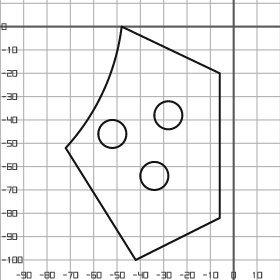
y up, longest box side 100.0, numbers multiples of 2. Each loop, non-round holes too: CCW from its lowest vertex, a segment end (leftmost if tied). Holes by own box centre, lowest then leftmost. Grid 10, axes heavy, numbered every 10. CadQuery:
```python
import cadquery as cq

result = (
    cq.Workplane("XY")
    .moveTo(-42.0, -100.0)
    .lineTo(-6.0, -82.0)
    .lineTo(-6.0, -20.0)
    .lineTo(-48.0, 0.0)
    .threePointArc((-56.0, -28.0), (-72.0, -52.0))
    .close()
    .moveTo(-34.0, -64.0)
    .circle(6.0)
    .moveTo(-52.0, -46.0)
    .circle(6.0)
    .moveTo(-28.0, -38.0)
    .circle(6.0)
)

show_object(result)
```